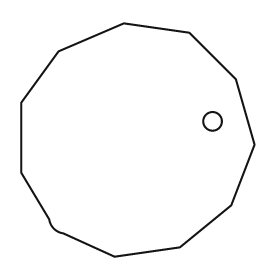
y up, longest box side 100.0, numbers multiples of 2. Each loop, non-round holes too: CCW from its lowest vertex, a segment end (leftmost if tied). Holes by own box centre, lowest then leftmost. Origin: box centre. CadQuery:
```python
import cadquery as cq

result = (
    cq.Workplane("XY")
    .moveTo(-10.0, -50.0)
    .lineTo(18.0, -46.0)
    .lineTo(40.0, -28.0)
    .lineTo(50.0, -2.0)
    .lineTo(42.0, 26.0)
    .lineTo(22.0, 46.0)
    .lineTo(-6.0, 50.0)
    .lineTo(-34.0, 38.0)
    .lineTo(-50.0, 16.0)
    .lineTo(-50.0, -14.0)
    .lineTo(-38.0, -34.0)
    .threePointArc((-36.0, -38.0), (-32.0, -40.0))
    .close()
    .moveTo(32.0, 8.0)
    .circle(4.0)
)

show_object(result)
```